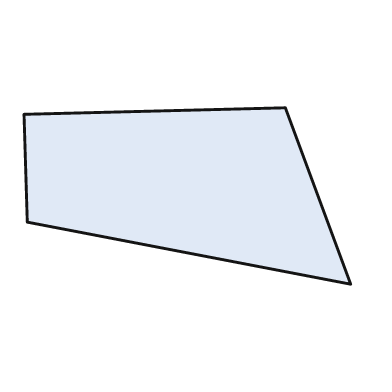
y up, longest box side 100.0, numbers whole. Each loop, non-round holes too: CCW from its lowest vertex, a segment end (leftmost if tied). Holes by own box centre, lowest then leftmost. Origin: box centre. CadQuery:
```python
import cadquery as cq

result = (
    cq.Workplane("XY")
    .moveTo(50.0, -27.0)
    .lineTo(30.0, 27.0)
    .lineTo(-50.0, 25.0)
    .lineTo(-49.0, -8.0)
    .close()
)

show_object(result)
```